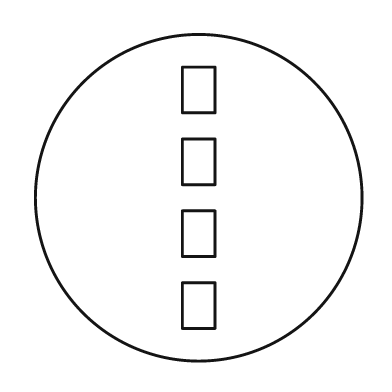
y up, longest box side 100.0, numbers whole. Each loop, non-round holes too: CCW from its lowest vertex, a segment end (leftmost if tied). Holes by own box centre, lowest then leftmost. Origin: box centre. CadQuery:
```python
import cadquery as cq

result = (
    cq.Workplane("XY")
    .moveTo(0.0, 0.0)
    .circle(50.0)
    .moveTo(-5.0, -40.0)
    .lineTo(5.0, -40.0)
    .lineTo(5.0, -26.0)
    .lineTo(-5.0, -26.0)
    .close()
    .moveTo(-5.0, -18.0)
    .lineTo(5.0, -18.0)
    .lineTo(5.0, -4.0)
    .lineTo(-5.0, -4.0)
    .close()
    .moveTo(-5.0, 4.0)
    .lineTo(5.0, 4.0)
    .lineTo(5.0, 18.0)
    .lineTo(-5.0, 18.0)
    .close()
    .moveTo(-5.0, 26.0)
    .lineTo(5.0, 26.0)
    .lineTo(5.0, 40.0)
    .lineTo(-5.0, 40.0)
    .close()
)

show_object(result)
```